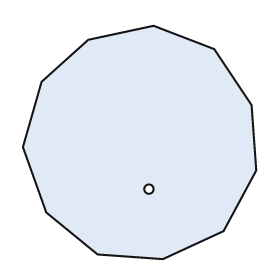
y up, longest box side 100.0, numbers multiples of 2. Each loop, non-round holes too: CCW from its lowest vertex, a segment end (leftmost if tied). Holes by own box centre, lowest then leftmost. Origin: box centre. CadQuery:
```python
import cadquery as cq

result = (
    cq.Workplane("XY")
    .moveTo(10.0, -50.0)
    .lineTo(36.0, -38.0)
    .lineTo(50.0, -12.0)
    .lineTo(48.0, 16.0)
    .lineTo(32.0, 40.0)
    .lineTo(6.0, 50.0)
    .lineTo(-22.0, 44.0)
    .lineTo(-42.0, 26.0)
    .lineTo(-50.0, -2.0)
    .lineTo(-40.0, -30.0)
    .lineTo(-18.0, -48.0)
    .close()
    .moveTo(4.0, -20.0)
    .circle(2.0)
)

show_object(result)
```